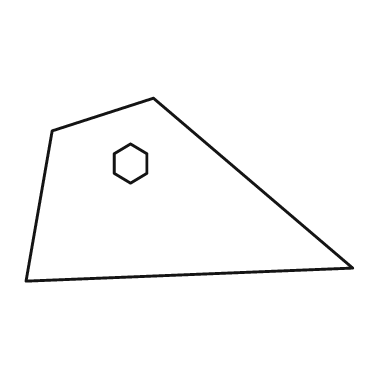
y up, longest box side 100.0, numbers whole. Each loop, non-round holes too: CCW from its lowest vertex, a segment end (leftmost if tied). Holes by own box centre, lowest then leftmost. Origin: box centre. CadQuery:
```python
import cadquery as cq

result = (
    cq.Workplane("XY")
    .moveTo(-50.0, -28.0)
    .lineTo(50.0, -24.0)
    .lineTo(-11.0, 28.0)
    .lineTo(-42.0, 18.0)
    .close()
    .moveTo(-18.0, 2.0)
    .lineTo(-13.0, 5.0)
    .lineTo(-13.0, 11.0)
    .lineTo(-18.0, 14.0)
    .lineTo(-23.0, 11.0)
    .lineTo(-23.0, 5.0)
    .close()
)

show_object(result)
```